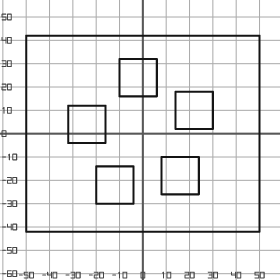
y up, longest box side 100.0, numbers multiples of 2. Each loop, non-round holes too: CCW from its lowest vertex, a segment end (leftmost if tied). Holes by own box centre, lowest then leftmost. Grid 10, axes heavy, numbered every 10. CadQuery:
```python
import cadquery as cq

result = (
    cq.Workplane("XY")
    .moveTo(-50.0, -42.0)
    .lineTo(50.0, -42.0)
    .lineTo(50.0, 42.0)
    .lineTo(-50.0, 42.0)
    .close()
    .moveTo(-20.0, -30.0)
    .lineTo(-4.0, -30.0)
    .lineTo(-4.0, -14.0)
    .lineTo(-20.0, -14.0)
    .close()
    .moveTo(8.0, -26.0)
    .lineTo(24.0, -26.0)
    .lineTo(24.0, -10.0)
    .lineTo(8.0, -10.0)
    .close()
    .moveTo(-32.0, -4.0)
    .lineTo(-16.0, -4.0)
    .lineTo(-16.0, 12.0)
    .lineTo(-32.0, 12.0)
    .close()
    .moveTo(14.0, 2.0)
    .lineTo(30.0, 2.0)
    .lineTo(30.0, 18.0)
    .lineTo(14.0, 18.0)
    .close()
    .moveTo(-10.0, 16.0)
    .lineTo(6.0, 16.0)
    .lineTo(6.0, 32.0)
    .lineTo(-10.0, 32.0)
    .close()
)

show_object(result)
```